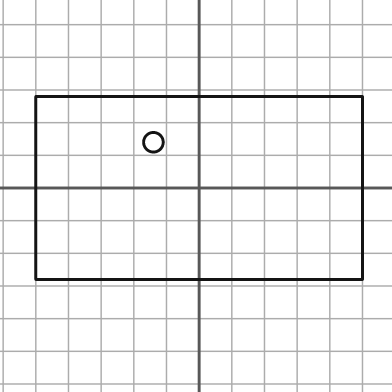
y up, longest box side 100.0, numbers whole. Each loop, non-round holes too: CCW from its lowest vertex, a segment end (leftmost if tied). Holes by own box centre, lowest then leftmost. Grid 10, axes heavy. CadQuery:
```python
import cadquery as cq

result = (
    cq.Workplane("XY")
    .moveTo(-50.0, -28.0)
    .lineTo(50.0, -28.0)
    .lineTo(50.0, 28.0)
    .lineTo(-50.0, 28.0)
    .close()
    .moveTo(-14.0, 14.0)
    .circle(3.0)
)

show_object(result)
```